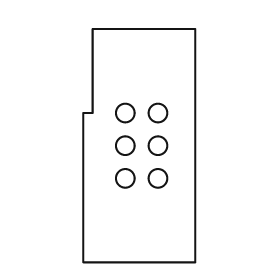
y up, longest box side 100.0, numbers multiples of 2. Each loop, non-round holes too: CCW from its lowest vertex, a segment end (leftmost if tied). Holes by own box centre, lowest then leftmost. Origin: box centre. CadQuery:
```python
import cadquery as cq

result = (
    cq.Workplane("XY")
    .moveTo(-24.0, -50.0)
    .lineTo(24.0, -50.0)
    .lineTo(24.0, 50.0)
    .lineTo(-20.0, 50.0)
    .lineTo(-20.0, 14.0)
    .lineTo(-24.0, 14.0)
    .close()
    .moveTo(-6.0, -14.0)
    .circle(4.0)
    .moveTo(8.0, -14.0)
    .circle(4.0)
    .moveTo(-6.0, 0.0)
    .circle(4.0)
    .moveTo(8.0, 0.0)
    .circle(4.0)
    .moveTo(-6.0, 14.0)
    .circle(4.0)
    .moveTo(8.0, 14.0)
    .circle(4.0)
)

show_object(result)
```